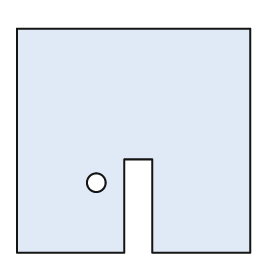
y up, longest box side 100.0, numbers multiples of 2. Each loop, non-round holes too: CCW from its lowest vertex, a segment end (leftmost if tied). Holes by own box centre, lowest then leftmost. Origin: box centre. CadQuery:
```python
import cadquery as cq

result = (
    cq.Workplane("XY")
    .moveTo(-50.0, -48.0)
    .lineTo(-4.0, -48.0)
    .lineTo(-4.0, -8.0)
    .lineTo(8.0, -8.0)
    .lineTo(8.0, -48.0)
    .lineTo(50.0, -48.0)
    .lineTo(50.0, 48.0)
    .lineTo(-50.0, 48.0)
    .close()
    .moveTo(-16.0, -18.0)
    .circle(4.0)
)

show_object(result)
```